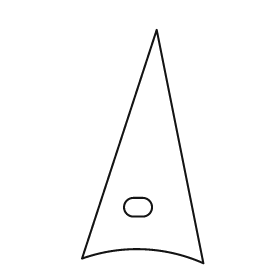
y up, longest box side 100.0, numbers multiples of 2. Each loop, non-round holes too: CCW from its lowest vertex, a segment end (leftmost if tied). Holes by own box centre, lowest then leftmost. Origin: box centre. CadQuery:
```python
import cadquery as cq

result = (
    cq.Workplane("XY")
    .moveTo(26.0, -50.0)
    .lineTo(6.0, 50.0)
    .lineTo(-26.0, -48.0)
    .threePointArc((0.0, -44.0), (26.0, -50.0))
    .close()
    .moveTo(-4.0, -30.0)
    .lineTo(0.0, -30.0)
    .threePointArc((4.0, -26.0), (0.0, -22.0))
    .lineTo(-4.0, -22.0)
    .threePointArc((-8.0, -26.0), (-4.0, -30.0))
    .close()
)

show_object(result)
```